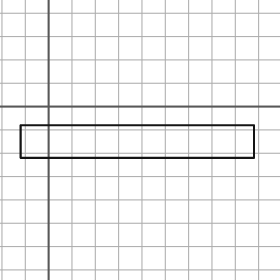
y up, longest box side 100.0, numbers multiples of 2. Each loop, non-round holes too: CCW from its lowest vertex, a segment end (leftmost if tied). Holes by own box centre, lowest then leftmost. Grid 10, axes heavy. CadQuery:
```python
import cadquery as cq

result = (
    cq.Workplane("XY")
    .moveTo(-12.0, -22.0)
    .lineTo(88.0, -22.0)
    .lineTo(88.0, -8.0)
    .lineTo(-12.0, -8.0)
    .close()
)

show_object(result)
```